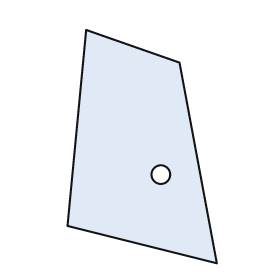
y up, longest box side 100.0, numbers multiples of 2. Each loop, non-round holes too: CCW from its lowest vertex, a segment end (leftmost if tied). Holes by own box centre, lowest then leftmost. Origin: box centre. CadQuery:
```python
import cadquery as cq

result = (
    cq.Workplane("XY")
    .moveTo(32.0, -50.0)
    .lineTo(16.0, 36.0)
    .lineTo(-24.0, 50.0)
    .lineTo(-32.0, -34.0)
    .close()
    .moveTo(8.0, -12.0)
    .circle(4.0)
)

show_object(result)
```